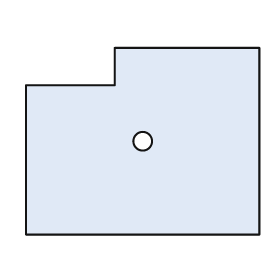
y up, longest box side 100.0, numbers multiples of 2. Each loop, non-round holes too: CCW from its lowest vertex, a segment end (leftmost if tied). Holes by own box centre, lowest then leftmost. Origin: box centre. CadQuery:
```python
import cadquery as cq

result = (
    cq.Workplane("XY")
    .moveTo(-50.0, -40.0)
    .lineTo(50.0, -40.0)
    .lineTo(50.0, 40.0)
    .lineTo(-12.0, 40.0)
    .lineTo(-12.0, 24.0)
    .lineTo(-50.0, 24.0)
    .close()
    .moveTo(0.0, 0.0)
    .circle(4.0)
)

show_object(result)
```